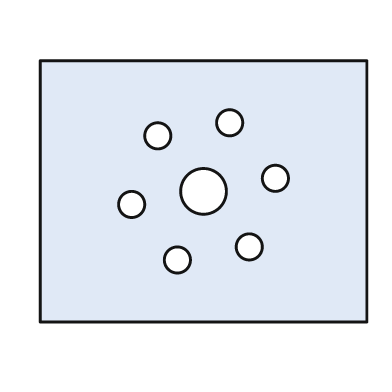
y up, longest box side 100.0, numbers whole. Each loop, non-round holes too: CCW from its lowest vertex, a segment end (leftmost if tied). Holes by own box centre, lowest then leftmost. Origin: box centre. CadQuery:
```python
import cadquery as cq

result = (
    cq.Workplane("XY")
    .moveTo(-50.0, -40.0)
    .lineTo(50.0, -40.0)
    .lineTo(50.0, 40.0)
    .lineTo(-50.0, 40.0)
    .close()
    .moveTo(-8.0, -21.0)
    .circle(4.0)
    .moveTo(14.0, -17.0)
    .circle(4.0)
    .moveTo(-22.0, -4.0)
    .circle(4.0)
    .moveTo(0.0, 0.0)
    .circle(7.0)
    .moveTo(22.0, 4.0)
    .circle(4.0)
    .moveTo(-14.0, 17.0)
    .circle(4.0)
    .moveTo(8.0, 21.0)
    .circle(4.0)
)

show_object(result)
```